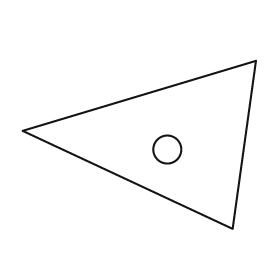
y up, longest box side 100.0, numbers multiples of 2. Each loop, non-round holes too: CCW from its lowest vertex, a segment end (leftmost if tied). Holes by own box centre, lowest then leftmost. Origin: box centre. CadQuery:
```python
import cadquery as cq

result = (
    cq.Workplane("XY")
    .moveTo(40.0, -36.0)
    .lineTo(50.0, 36.0)
    .lineTo(-50.0, 6.0)
    .close()
    .moveTo(12.0, -2.0)
    .circle(6.0)
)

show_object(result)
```